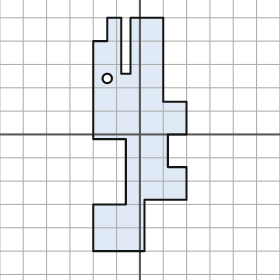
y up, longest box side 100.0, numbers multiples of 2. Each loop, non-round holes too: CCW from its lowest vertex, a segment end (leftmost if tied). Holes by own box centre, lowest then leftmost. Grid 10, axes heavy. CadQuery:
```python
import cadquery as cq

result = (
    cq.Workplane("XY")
    .moveTo(-20.0, -50.0)
    .lineTo(2.0, -50.0)
    .lineTo(2.0, -28.0)
    .lineTo(20.0, -28.0)
    .lineTo(20.0, -14.0)
    .lineTo(12.0, -14.0)
    .lineTo(12.0, 0.0)
    .lineTo(20.0, 0.0)
    .lineTo(20.0, 14.0)
    .lineTo(10.0, 14.0)
    .lineTo(10.0, 50.0)
    .lineTo(-4.0, 50.0)
    .lineTo(-4.0, 26.0)
    .lineTo(-8.0, 26.0)
    .lineTo(-8.0, 50.0)
    .lineTo(-14.0, 50.0)
    .lineTo(-14.0, 40.0)
    .lineTo(-20.0, 40.0)
    .lineTo(-20.0, -2.0)
    .lineTo(-6.0, -2.0)
    .lineTo(-6.0, -30.0)
    .lineTo(-20.0, -30.0)
    .close()
    .moveTo(-14.0, 24.0)
    .circle(2.0)
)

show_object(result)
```